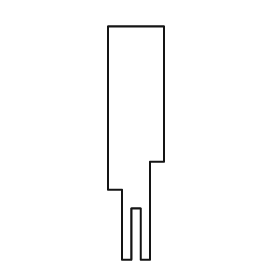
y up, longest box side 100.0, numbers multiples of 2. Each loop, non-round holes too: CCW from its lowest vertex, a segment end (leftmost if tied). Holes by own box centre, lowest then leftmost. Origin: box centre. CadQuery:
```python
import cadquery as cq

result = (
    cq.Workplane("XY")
    .moveTo(-6.0, -50.0)
    .lineTo(-2.0, -50.0)
    .lineTo(-2.0, -28.0)
    .lineTo(2.0, -28.0)
    .lineTo(2.0, -50.0)
    .lineTo(6.0, -50.0)
    .lineTo(6.0, -8.0)
    .lineTo(12.0, -8.0)
    .lineTo(12.0, 50.0)
    .lineTo(-12.0, 50.0)
    .lineTo(-12.0, -20.0)
    .lineTo(-6.0, -20.0)
    .close()
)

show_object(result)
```